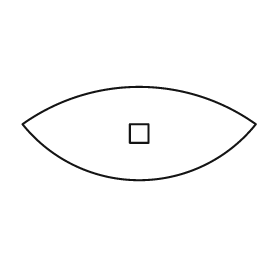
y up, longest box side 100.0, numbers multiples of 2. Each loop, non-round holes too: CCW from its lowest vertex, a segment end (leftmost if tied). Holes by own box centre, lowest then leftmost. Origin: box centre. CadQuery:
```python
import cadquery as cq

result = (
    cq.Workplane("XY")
    .moveTo(-50.0, 4.0)
    .threePointArc((0.0, -20.0), (50.0, 4.0))
    .threePointArc((0.0, 20.0), (-50.0, 4.0))
    .close()
    .moveTo(-4.0, -4.0)
    .lineTo(4.0, -4.0)
    .lineTo(4.0, 4.0)
    .lineTo(-4.0, 4.0)
    .close()
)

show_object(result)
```